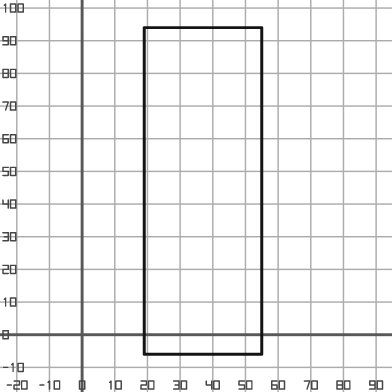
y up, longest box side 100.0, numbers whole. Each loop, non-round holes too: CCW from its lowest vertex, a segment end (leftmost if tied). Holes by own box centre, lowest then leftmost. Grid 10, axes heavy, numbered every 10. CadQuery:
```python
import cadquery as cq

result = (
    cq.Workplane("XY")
    .moveTo(19.0, -6.0)
    .lineTo(55.0, -6.0)
    .lineTo(55.0, 94.0)
    .lineTo(19.0, 94.0)
    .close()
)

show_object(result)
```